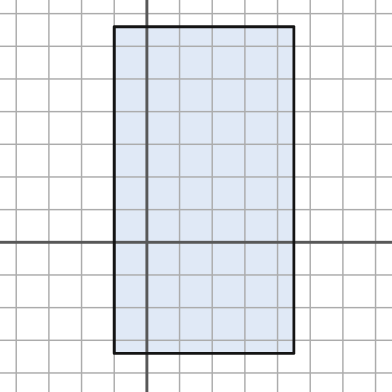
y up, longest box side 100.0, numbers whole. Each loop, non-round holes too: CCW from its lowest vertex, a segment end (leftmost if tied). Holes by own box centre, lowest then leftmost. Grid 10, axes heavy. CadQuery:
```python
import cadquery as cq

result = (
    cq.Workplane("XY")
    .moveTo(-10.0, -34.0)
    .lineTo(45.0, -34.0)
    .lineTo(45.0, 66.0)
    .lineTo(-10.0, 66.0)
    .close()
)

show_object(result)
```